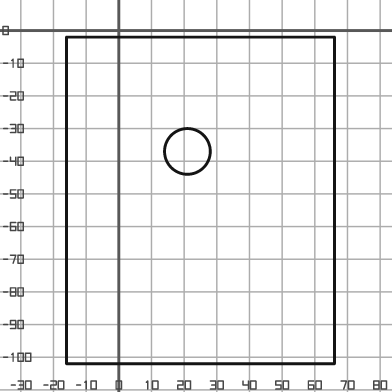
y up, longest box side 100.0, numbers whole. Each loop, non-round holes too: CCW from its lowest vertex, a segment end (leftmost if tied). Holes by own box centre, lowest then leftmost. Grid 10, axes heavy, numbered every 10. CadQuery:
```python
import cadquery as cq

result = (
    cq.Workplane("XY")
    .moveTo(-16.0, -102.0)
    .lineTo(66.0, -102.0)
    .lineTo(66.0, -2.0)
    .lineTo(-16.0, -2.0)
    .close()
    .moveTo(21.0, -37.0)
    .circle(7.0)
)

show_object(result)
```